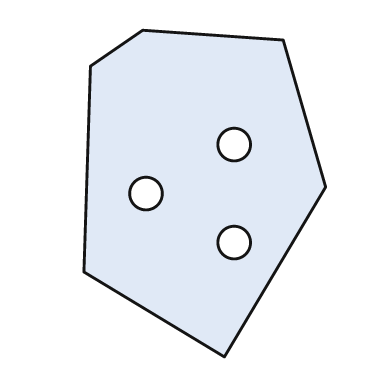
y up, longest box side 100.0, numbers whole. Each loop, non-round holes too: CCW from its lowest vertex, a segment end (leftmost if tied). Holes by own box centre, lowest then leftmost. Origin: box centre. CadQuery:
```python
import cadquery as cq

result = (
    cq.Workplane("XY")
    .moveTo(6.0, -50.0)
    .lineTo(37.0, 2.0)
    .lineTo(24.0, 47.0)
    .lineTo(-19.0, 50.0)
    .lineTo(-35.0, 39.0)
    .lineTo(-37.0, -24.0)
    .close()
    .moveTo(9.0, -15.0)
    .circle(5.0)
    .moveTo(-18.0, 0.0)
    .circle(5.0)
    .moveTo(9.0, 15.0)
    .circle(5.0)
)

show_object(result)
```